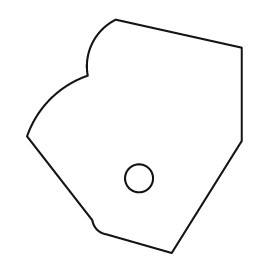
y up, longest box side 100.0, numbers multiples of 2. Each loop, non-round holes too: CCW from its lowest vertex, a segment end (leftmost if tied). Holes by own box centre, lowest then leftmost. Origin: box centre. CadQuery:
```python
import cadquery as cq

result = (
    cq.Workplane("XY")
    .moveTo(16.0, -50.0)
    .lineTo(46.0, -2.0)
    .lineTo(46.0, 38.0)
    .lineTo(-8.0, 50.0)
    .threePointArc((-18.0, 40.0), (-20.0, 26.0))
    .threePointArc((-36.0, 16.0), (-46.0, 0.0))
    .lineTo(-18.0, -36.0)
    .threePointArc((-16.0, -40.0), (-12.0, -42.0))
    .close()
    .moveTo(2.0, -18.0)
    .circle(6.0)
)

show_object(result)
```